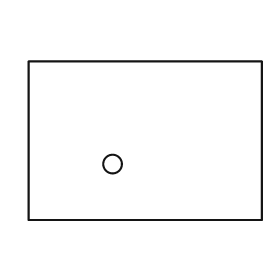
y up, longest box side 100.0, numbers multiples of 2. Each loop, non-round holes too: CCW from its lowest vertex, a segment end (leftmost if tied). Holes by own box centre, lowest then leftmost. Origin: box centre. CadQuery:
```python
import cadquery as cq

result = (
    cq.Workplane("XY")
    .moveTo(-50.0, -34.0)
    .lineTo(50.0, -34.0)
    .lineTo(50.0, 34.0)
    .lineTo(-50.0, 34.0)
    .close()
    .moveTo(-14.0, -10.0)
    .circle(4.0)
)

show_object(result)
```